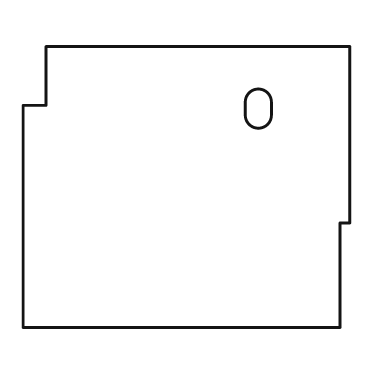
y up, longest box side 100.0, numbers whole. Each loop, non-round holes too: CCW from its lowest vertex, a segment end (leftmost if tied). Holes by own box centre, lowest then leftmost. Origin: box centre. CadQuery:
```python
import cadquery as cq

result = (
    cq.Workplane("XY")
    .moveTo(-50.0, -43.0)
    .lineTo(47.0, -43.0)
    .lineTo(47.0, -11.0)
    .lineTo(50.0, -11.0)
    .lineTo(50.0, 43.0)
    .lineTo(-43.0, 43.0)
    .lineTo(-43.0, 25.0)
    .lineTo(-50.0, 25.0)
    .close()
    .moveTo(18.0, 22.0)
    .threePointArc((22.0, 18.0), (26.0, 22.0))
    .lineTo(26.0, 26.0)
    .threePointArc((22.0, 30.0), (18.0, 26.0))
    .close()
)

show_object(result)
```